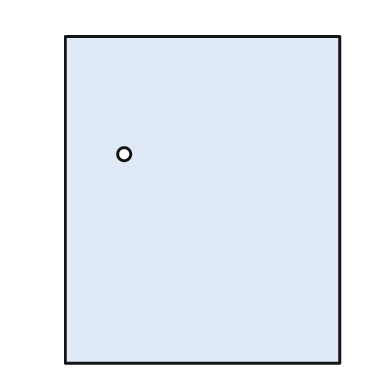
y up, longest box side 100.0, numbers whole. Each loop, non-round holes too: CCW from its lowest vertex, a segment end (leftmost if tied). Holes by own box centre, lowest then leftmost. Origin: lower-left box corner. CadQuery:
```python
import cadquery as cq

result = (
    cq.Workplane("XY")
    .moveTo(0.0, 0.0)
    .lineTo(84.0, 0.0)
    .lineTo(84.0, 100.0)
    .lineTo(0.0, 100.0)
    .close()
    .moveTo(18.0, 64.0)
    .circle(2.0)
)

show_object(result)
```